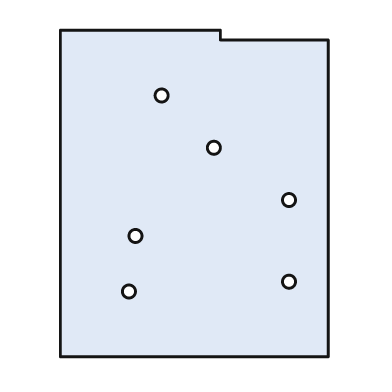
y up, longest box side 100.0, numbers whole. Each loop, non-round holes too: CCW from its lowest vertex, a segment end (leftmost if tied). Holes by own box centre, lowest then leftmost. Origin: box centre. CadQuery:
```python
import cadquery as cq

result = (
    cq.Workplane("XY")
    .moveTo(-41.0, -50.0)
    .lineTo(41.0, -50.0)
    .lineTo(41.0, 47.0)
    .lineTo(8.0, 47.0)
    .lineTo(8.0, 50.0)
    .lineTo(-41.0, 50.0)
    .close()
    .moveTo(-20.0, -30.0)
    .circle(2.0)
    .moveTo(29.0, -27.0)
    .circle(2.0)
    .moveTo(-18.0, -13.0)
    .circle(2.0)
    .moveTo(29.0, -2.0)
    .circle(2.0)
    .moveTo(6.0, 14.0)
    .circle(2.0)
    .moveTo(-10.0, 30.0)
    .circle(2.0)
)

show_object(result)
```